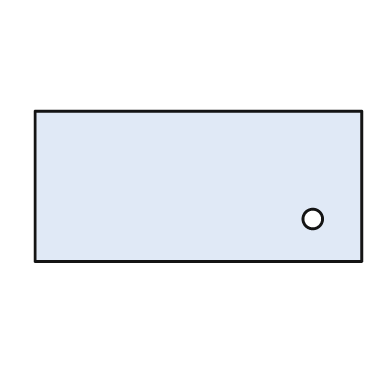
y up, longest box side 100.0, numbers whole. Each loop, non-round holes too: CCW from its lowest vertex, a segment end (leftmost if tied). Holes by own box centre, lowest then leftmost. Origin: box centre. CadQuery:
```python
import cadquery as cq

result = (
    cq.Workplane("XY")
    .moveTo(-50.0, -23.0)
    .lineTo(50.0, -23.0)
    .lineTo(50.0, 23.0)
    .lineTo(-50.0, 23.0)
    .close()
    .moveTo(35.0, -10.0)
    .circle(3.0)
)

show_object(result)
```